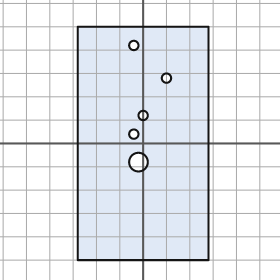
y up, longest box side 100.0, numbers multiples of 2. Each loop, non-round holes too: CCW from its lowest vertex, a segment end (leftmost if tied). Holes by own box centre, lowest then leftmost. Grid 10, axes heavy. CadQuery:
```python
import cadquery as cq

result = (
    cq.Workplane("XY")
    .moveTo(-28.0, -50.0)
    .lineTo(28.0, -50.0)
    .lineTo(28.0, 50.0)
    .lineTo(-28.0, 50.0)
    .close()
    .moveTo(-2.0, -8.0)
    .circle(4.0)
    .moveTo(-4.0, 4.0)
    .circle(2.0)
    .moveTo(0.0, 12.0)
    .circle(2.0)
    .moveTo(10.0, 28.0)
    .circle(2.0)
    .moveTo(-4.0, 42.0)
    .circle(2.0)
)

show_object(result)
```